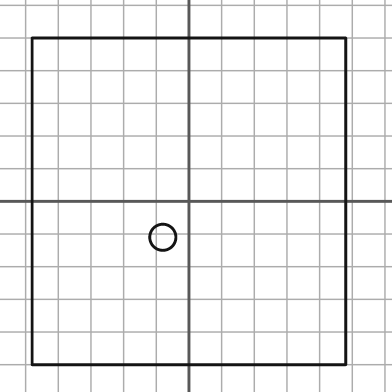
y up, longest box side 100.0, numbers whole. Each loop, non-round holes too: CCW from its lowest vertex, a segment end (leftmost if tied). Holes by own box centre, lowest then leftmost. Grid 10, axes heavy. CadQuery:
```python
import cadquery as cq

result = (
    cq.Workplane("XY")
    .moveTo(-48.0, -50.0)
    .lineTo(48.0, -50.0)
    .lineTo(48.0, 50.0)
    .lineTo(-48.0, 50.0)
    .close()
    .moveTo(-8.0, -11.0)
    .circle(4.0)
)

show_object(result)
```